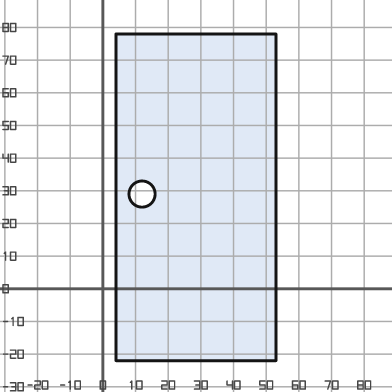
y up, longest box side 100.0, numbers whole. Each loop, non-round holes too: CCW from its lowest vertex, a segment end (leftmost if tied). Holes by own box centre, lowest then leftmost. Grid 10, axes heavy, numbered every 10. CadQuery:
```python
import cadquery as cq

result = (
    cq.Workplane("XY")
    .moveTo(4.0, -22.0)
    .lineTo(53.0, -22.0)
    .lineTo(53.0, 78.0)
    .lineTo(4.0, 78.0)
    .close()
    .moveTo(12.0, 29.0)
    .circle(4.0)
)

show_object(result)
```